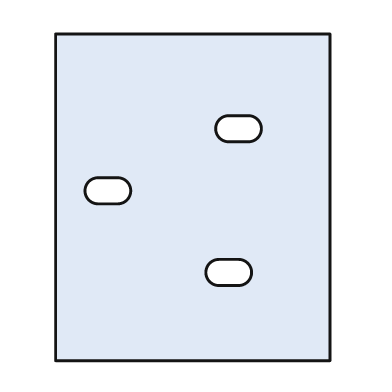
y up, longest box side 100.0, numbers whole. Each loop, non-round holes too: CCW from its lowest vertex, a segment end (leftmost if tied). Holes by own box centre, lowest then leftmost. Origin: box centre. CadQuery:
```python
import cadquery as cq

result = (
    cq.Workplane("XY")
    .moveTo(-42.0, -50.0)
    .lineTo(42.0, -50.0)
    .lineTo(42.0, 50.0)
    .lineTo(-42.0, 50.0)
    .close()
    .moveTo(8.0, -27.0)
    .lineTo(14.0, -27.0)
    .threePointArc((18.0, -23.0), (14.0, -19.0))
    .lineTo(8.0, -19.0)
    .threePointArc((4.0, -23.0), (8.0, -27.0))
    .close()
    .moveTo(-29.0, -2.0)
    .lineTo(-23.0, -2.0)
    .threePointArc((-19.0, 2.0), (-23.0, 6.0))
    .lineTo(-29.0, 6.0)
    .threePointArc((-33.0, 2.0), (-29.0, -2.0))
    .close()
    .moveTo(11.0, 17.0)
    .lineTo(17.0, 17.0)
    .threePointArc((21.0, 21.0), (17.0, 25.0))
    .lineTo(11.0, 25.0)
    .threePointArc((7.0, 21.0), (11.0, 17.0))
    .close()
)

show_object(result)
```